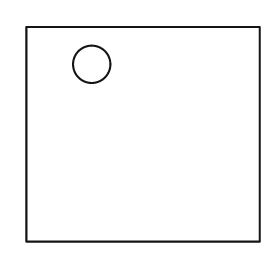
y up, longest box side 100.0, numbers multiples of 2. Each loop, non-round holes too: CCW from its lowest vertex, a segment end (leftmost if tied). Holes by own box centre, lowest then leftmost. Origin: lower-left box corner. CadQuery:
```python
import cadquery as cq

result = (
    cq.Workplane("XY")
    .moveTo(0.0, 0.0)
    .lineTo(100.0, 0.0)
    .lineTo(100.0, 92.0)
    .lineTo(0.0, 92.0)
    .close()
    .moveTo(28.0, 76.0)
    .circle(8.0)
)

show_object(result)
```